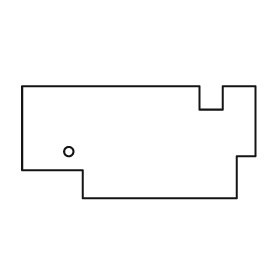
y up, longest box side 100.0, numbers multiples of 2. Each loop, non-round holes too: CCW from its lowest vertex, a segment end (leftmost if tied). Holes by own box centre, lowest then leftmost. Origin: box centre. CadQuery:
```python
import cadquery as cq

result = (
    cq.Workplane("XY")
    .moveTo(-24.0, -24.0)
    .lineTo(42.0, -24.0)
    .lineTo(42.0, -6.0)
    .lineTo(50.0, -6.0)
    .lineTo(50.0, 24.0)
    .lineTo(36.0, 24.0)
    .lineTo(36.0, 14.0)
    .lineTo(26.0, 14.0)
    .lineTo(26.0, 24.0)
    .lineTo(-50.0, 24.0)
    .lineTo(-50.0, -12.0)
    .lineTo(-24.0, -12.0)
    .close()
    .moveTo(-30.0, -4.0)
    .circle(2.0)
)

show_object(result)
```